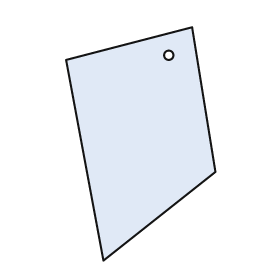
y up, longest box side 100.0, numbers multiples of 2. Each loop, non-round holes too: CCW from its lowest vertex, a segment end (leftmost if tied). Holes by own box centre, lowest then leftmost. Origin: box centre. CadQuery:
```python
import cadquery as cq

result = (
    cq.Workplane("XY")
    .moveTo(-16.0, -50.0)
    .lineTo(32.0, -12.0)
    .lineTo(22.0, 50.0)
    .lineTo(-32.0, 36.0)
    .close()
    .moveTo(12.0, 38.0)
    .circle(2.0)
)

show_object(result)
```